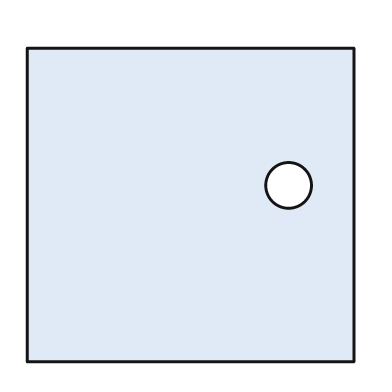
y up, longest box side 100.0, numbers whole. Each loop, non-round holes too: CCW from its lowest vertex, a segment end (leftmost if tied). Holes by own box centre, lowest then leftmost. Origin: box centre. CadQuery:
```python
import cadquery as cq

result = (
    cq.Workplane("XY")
    .moveTo(-50.0, -48.0)
    .lineTo(50.0, -48.0)
    .lineTo(50.0, 48.0)
    .lineTo(-50.0, 48.0)
    .close()
    .moveTo(30.0, 6.0)
    .circle(7.0)
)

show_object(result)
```